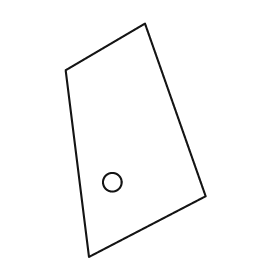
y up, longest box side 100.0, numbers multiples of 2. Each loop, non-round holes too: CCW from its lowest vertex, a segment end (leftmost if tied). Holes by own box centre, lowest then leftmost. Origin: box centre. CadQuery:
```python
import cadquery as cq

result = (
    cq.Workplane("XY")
    .moveTo(-20.0, -50.0)
    .lineTo(30.0, -24.0)
    .lineTo(4.0, 50.0)
    .lineTo(-30.0, 30.0)
    .close()
    .moveTo(-10.0, -18.0)
    .circle(4.0)
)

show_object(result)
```